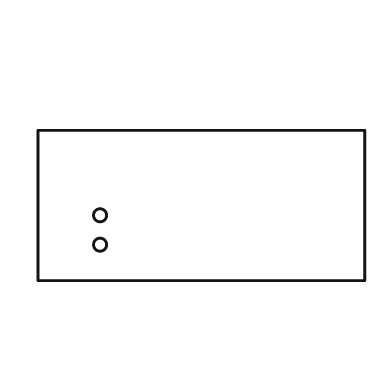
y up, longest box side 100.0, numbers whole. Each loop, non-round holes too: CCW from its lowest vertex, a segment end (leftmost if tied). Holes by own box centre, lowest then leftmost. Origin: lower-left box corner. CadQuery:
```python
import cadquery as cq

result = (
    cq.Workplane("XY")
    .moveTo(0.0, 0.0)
    .lineTo(100.0, 0.0)
    .lineTo(100.0, 46.0)
    .lineTo(0.0, 46.0)
    .close()
    .moveTo(19.0, 11.0)
    .circle(2.0)
    .moveTo(19.0, 20.0)
    .circle(2.0)
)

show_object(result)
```